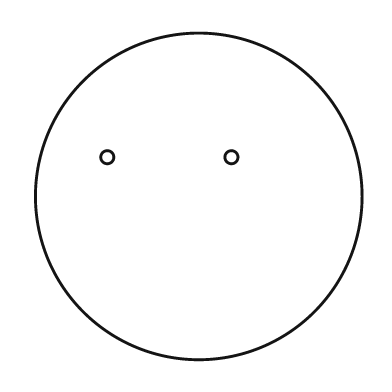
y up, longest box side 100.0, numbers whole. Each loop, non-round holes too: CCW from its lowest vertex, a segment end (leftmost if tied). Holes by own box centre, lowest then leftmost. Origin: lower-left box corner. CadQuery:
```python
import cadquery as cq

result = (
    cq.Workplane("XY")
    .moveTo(50.0, 50.0)
    .circle(50.0)
    .moveTo(22.0, 62.0)
    .circle(2.0)
    .moveTo(60.0, 62.0)
    .circle(2.0)
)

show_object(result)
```